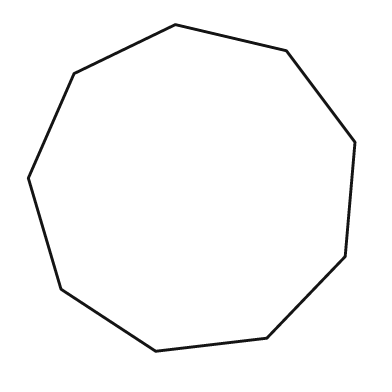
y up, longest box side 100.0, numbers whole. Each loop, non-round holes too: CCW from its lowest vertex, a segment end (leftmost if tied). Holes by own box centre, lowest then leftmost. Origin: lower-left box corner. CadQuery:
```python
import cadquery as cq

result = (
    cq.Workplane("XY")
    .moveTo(39.0, 0.0)
    .lineTo(73.0, 4.0)
    .lineTo(97.0, 29.0)
    .lineTo(100.0, 64.0)
    .lineTo(79.0, 92.0)
    .lineTo(45.0, 100.0)
    .lineTo(14.0, 85.0)
    .lineTo(0.0, 53.0)
    .lineTo(10.0, 19.0)
    .close()
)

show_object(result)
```